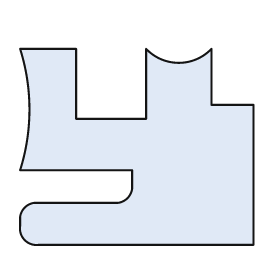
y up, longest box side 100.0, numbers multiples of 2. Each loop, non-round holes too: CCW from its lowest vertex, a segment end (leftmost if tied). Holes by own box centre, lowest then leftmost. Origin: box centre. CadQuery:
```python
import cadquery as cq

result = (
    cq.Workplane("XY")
    .moveTo(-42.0, -42.0)
    .lineTo(50.0, -42.0)
    .lineTo(50.0, 18.0)
    .lineTo(32.0, 18.0)
    .lineTo(32.0, 42.0)
    .threePointArc((18.0, 36.0), (4.0, 42.0))
    .lineTo(4.0, 12.0)
    .lineTo(-26.0, 12.0)
    .lineTo(-26.0, 42.0)
    .lineTo(-50.0, 42.0)
    .threePointArc((-46.0, 16.0), (-50.0, -10.0))
    .lineTo(-2.0, -10.0)
    .lineTo(-2.0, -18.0)
    .threePointArc((-4.0, -22.0), (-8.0, -24.0))
    .lineTo(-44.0, -24.0)
    .threePointArc((-48.0, -26.0), (-50.0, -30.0))
    .lineTo(-50.0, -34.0)
    .threePointArc((-48.0, -40.0), (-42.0, -42.0))
    .close()
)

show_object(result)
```